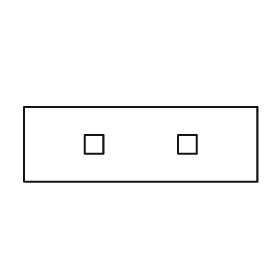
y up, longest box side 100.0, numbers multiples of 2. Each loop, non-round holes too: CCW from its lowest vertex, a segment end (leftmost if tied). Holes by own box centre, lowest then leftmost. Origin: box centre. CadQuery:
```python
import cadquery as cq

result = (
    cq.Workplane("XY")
    .moveTo(-50.0, -16.0)
    .lineTo(50.0, -16.0)
    .lineTo(50.0, 16.0)
    .lineTo(-50.0, 16.0)
    .close()
    .moveTo(-24.0, -4.0)
    .lineTo(-16.0, -4.0)
    .lineTo(-16.0, 4.0)
    .lineTo(-24.0, 4.0)
    .close()
    .moveTo(16.0, -4.0)
    .lineTo(24.0, -4.0)
    .lineTo(24.0, 4.0)
    .lineTo(16.0, 4.0)
    .close()
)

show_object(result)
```